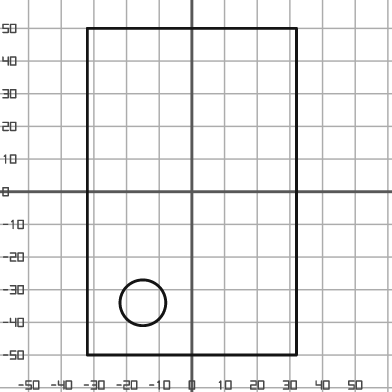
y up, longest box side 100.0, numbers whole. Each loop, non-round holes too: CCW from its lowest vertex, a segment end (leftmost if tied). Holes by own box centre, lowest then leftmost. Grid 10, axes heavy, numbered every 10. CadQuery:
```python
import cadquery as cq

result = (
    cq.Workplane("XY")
    .moveTo(-32.0, -50.0)
    .lineTo(32.0, -50.0)
    .lineTo(32.0, 50.0)
    .lineTo(-32.0, 50.0)
    .close()
    .moveTo(-15.0, -34.0)
    .circle(7.0)
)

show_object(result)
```